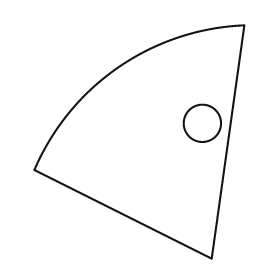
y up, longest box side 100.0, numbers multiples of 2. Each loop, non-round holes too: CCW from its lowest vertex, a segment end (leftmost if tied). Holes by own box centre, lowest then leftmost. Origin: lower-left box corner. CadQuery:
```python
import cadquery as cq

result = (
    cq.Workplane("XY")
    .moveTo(76.0, 0.0)
    .lineTo(90.0, 100.0)
    .threePointArc((36.0, 82.0), (0.0, 38.0))
    .close()
    .moveTo(72.0, 58.0)
    .circle(8.0)
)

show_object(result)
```